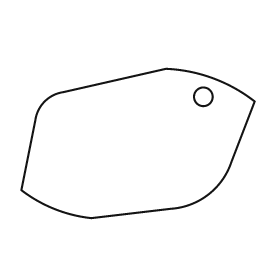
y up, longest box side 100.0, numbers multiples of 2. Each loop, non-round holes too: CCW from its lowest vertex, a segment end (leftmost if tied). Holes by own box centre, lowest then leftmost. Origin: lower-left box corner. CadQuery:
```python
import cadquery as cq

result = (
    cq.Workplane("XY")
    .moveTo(30.0, 0.0)
    .lineTo(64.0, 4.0)
    .threePointArc((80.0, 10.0), (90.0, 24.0))
    .lineTo(100.0, 50.0)
    .threePointArc((82.0, 60.0), (62.0, 64.0))
    .lineTo(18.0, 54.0)
    .threePointArc((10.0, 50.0), (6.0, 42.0))
    .lineTo(0.0, 12.0)
    .threePointArc((14.0, 4.0), (30.0, 0.0))
    .close()
    .moveTo(78.0, 52.0)
    .circle(4.0)
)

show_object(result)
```